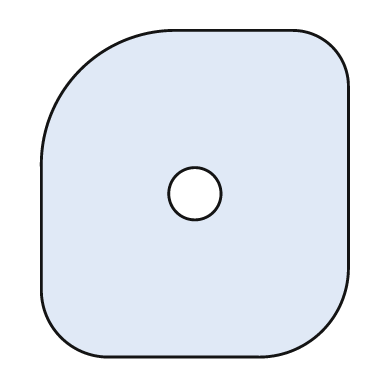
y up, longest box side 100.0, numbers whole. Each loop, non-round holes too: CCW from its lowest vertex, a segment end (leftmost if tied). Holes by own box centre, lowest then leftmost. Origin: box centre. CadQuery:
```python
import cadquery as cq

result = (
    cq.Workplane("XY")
    .moveTo(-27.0, -50.0)
    .lineTo(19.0, -50.0)
    .threePointArc((39.0, -42.0), (47.0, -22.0))
    .lineTo(47.0, 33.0)
    .threePointArc((42.0, 45.0), (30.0, 50.0))
    .lineTo(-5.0, 50.0)
    .threePointArc((-35.0, 38.0), (-47.0, 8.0))
    .lineTo(-47.0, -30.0)
    .threePointArc((-41.0, -44.0), (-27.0, -50.0))
    .close()
    .moveTo(0.0, 0.0)
    .circle(8.0)
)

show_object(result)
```